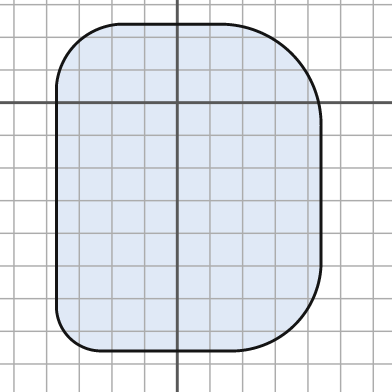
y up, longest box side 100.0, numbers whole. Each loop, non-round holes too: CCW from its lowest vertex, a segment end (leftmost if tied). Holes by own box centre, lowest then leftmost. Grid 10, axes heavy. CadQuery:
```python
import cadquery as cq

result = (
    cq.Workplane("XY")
    .moveTo(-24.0, -76.0)
    .lineTo(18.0, -76.0)
    .threePointArc((36.0, -68.0), (44.0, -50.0))
    .lineTo(44.0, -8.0)
    .threePointArc((35.0, 15.0), (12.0, 24.0))
    .lineTo(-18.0, 24.0)
    .threePointArc((-31.0, 18.0), (-37.0, 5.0))
    .lineTo(-37.0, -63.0)
    .threePointArc((-33.0, -72.0), (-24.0, -76.0))
    .close()
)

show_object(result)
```